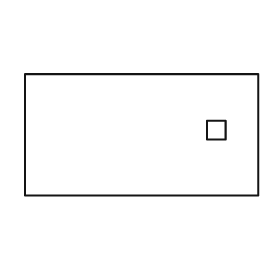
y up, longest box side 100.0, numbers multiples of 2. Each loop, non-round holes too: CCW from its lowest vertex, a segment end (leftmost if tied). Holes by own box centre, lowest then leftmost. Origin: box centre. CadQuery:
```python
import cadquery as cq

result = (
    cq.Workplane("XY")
    .moveTo(-50.0, -26.0)
    .lineTo(50.0, -26.0)
    .lineTo(50.0, 26.0)
    .lineTo(-50.0, 26.0)
    .close()
    .moveTo(28.0, -2.0)
    .lineTo(36.0, -2.0)
    .lineTo(36.0, 6.0)
    .lineTo(28.0, 6.0)
    .close()
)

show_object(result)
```